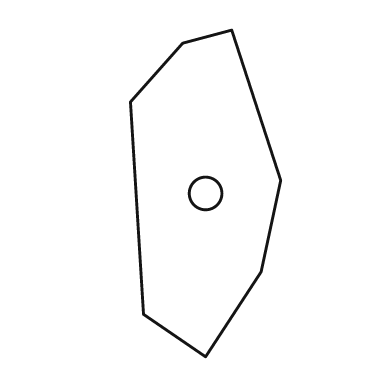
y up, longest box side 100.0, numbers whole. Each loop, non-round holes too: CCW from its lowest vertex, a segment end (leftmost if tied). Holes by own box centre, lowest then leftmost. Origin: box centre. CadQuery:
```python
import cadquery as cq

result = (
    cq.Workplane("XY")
    .moveTo(0.0, -50.0)
    .lineTo(17.0, -24.0)
    .lineTo(23.0, 4.0)
    .lineTo(8.0, 50.0)
    .lineTo(-7.0, 46.0)
    .lineTo(-23.0, 28.0)
    .lineTo(-19.0, -37.0)
    .close()
    .moveTo(0.0, 0.0)
    .circle(5.0)
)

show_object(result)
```